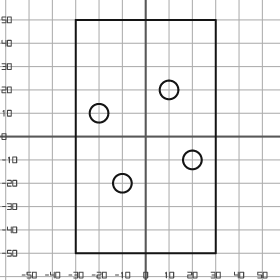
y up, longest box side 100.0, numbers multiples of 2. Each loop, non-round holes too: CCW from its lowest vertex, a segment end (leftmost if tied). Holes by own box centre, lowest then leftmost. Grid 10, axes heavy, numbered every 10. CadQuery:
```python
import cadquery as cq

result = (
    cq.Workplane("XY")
    .moveTo(-30.0, -50.0)
    .lineTo(30.0, -50.0)
    .lineTo(30.0, 50.0)
    .lineTo(-30.0, 50.0)
    .close()
    .moveTo(-10.0, -20.0)
    .circle(4.0)
    .moveTo(20.0, -10.0)
    .circle(4.0)
    .moveTo(-20.0, 10.0)
    .circle(4.0)
    .moveTo(10.0, 20.0)
    .circle(4.0)
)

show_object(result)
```